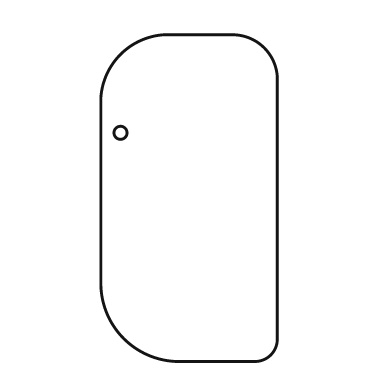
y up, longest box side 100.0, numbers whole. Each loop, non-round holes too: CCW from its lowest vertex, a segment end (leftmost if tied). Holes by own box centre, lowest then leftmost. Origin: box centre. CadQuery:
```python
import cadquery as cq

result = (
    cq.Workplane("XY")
    .moveTo(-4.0, -50.0)
    .lineTo(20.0, -50.0)
    .threePointArc((25.0, -48.0), (27.0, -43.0))
    .lineTo(27.0, 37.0)
    .threePointArc((23.0, 46.0), (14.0, 50.0))
    .lineTo(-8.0, 50.0)
    .threePointArc((-21.0, 44.0), (-27.0, 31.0))
    .lineTo(-27.0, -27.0)
    .threePointArc((-20.0, -43.0), (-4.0, -50.0))
    .close()
    .moveTo(-21.0, 20.0)
    .circle(2.0)
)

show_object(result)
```